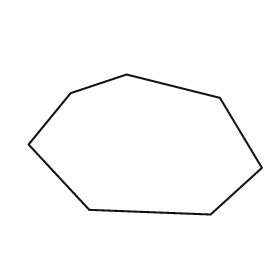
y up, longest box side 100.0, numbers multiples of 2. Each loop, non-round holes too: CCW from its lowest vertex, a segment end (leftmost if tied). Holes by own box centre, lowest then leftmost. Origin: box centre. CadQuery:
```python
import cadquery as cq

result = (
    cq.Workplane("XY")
    .moveTo(28.0, -30.0)
    .lineTo(50.0, -10.0)
    .lineTo(32.0, 20.0)
    .lineTo(-8.0, 30.0)
    .lineTo(-32.0, 22.0)
    .lineTo(-50.0, 0.0)
    .lineTo(-24.0, -28.0)
    .close()
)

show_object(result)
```